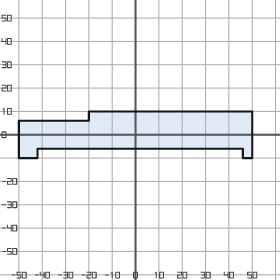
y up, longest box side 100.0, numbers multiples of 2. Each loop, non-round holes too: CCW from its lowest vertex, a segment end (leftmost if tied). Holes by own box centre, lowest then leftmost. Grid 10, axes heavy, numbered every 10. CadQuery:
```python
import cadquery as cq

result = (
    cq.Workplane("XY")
    .moveTo(-50.0, -10.0)
    .lineTo(-42.0, -10.0)
    .lineTo(-42.0, -6.0)
    .lineTo(46.0, -6.0)
    .lineTo(46.0, -10.0)
    .lineTo(50.0, -10.0)
    .lineTo(50.0, 10.0)
    .lineTo(-20.0, 10.0)
    .lineTo(-20.0, 6.0)
    .lineTo(-50.0, 6.0)
    .close()
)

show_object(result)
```